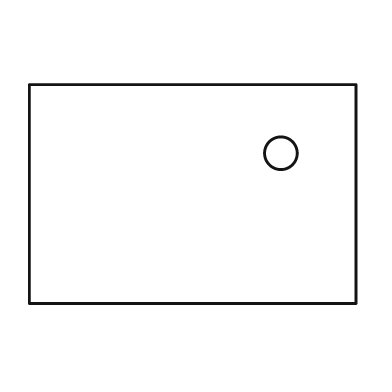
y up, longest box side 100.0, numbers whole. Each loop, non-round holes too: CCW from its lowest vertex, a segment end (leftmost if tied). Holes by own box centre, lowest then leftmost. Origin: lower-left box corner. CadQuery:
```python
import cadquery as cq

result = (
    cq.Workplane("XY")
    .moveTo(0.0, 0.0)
    .lineTo(100.0, 0.0)
    .lineTo(100.0, 67.0)
    .lineTo(0.0, 67.0)
    .close()
    .moveTo(77.0, 46.0)
    .circle(5.0)
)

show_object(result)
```